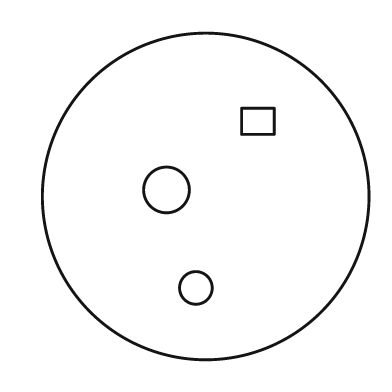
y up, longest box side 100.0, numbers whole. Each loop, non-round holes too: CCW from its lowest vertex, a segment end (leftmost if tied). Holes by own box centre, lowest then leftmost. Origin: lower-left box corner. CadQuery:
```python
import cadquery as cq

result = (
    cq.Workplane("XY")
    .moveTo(50.0, 50.0)
    .circle(50.0)
    .moveTo(47.0, 22.0)
    .circle(5.0)
    .moveTo(38.0, 52.0)
    .circle(7.0)
    .moveTo(61.0, 69.0)
    .lineTo(71.0, 69.0)
    .lineTo(71.0, 77.0)
    .lineTo(61.0, 77.0)
    .close()
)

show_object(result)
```